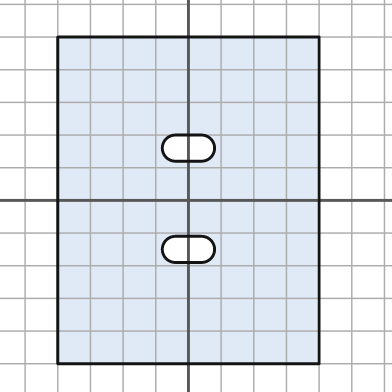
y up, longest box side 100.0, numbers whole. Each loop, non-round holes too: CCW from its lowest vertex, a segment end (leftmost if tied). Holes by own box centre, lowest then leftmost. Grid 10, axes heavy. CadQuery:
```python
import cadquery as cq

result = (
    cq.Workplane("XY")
    .moveTo(-40.0, -50.0)
    .lineTo(40.0, -50.0)
    .lineTo(40.0, 50.0)
    .lineTo(-40.0, 50.0)
    .close()
    .moveTo(-4.0, -19.0)
    .lineTo(4.0, -19.0)
    .threePointArc((8.0, -15.0), (4.0, -11.0))
    .lineTo(-4.0, -11.0)
    .threePointArc((-8.0, -15.0), (-4.0, -19.0))
    .close()
    .moveTo(-4.0, 12.0)
    .lineTo(4.0, 12.0)
    .threePointArc((8.0, 16.0), (4.0, 20.0))
    .lineTo(-4.0, 20.0)
    .threePointArc((-8.0, 16.0), (-4.0, 12.0))
    .close()
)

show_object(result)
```